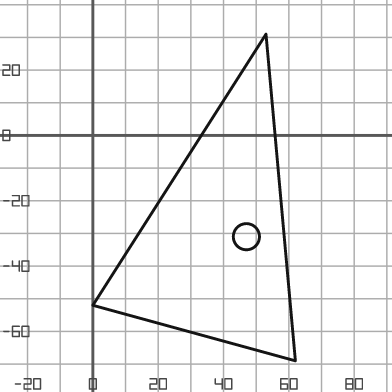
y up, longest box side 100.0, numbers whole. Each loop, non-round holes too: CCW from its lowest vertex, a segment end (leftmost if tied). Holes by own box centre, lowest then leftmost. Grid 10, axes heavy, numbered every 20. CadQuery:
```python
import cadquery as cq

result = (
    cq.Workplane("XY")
    .moveTo(62.0, -69.0)
    .lineTo(53.0, 31.0)
    .lineTo(0.0, -52.0)
    .close()
    .moveTo(47.0, -31.0)
    .circle(4.0)
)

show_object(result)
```